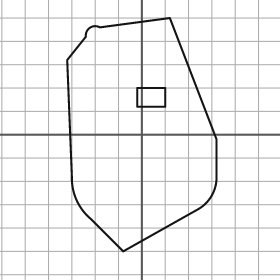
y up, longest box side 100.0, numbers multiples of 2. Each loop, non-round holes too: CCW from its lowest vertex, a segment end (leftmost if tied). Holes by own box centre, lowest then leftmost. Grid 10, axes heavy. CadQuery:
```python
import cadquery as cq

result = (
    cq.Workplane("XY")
    .moveTo(-8.0, -50.0)
    .lineTo(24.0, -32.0)
    .threePointArc((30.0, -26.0), (32.0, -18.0))
    .lineTo(32.0, -2.0)
    .lineTo(12.0, 50.0)
    .lineTo(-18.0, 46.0)
    .threePointArc((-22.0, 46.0), (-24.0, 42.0))
    .lineTo(-32.0, 32.0)
    .lineTo(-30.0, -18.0)
    .threePointArc((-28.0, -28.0), (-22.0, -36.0))
    .close()
    .moveTo(-2.0, 12.0)
    .lineTo(10.0, 12.0)
    .lineTo(10.0, 20.0)
    .lineTo(-2.0, 20.0)
    .close()
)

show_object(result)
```